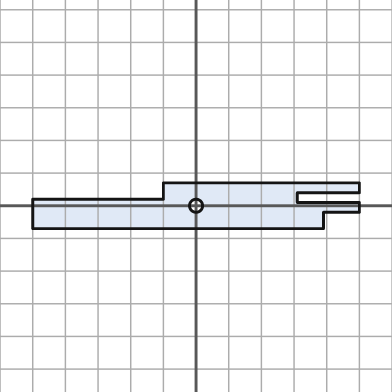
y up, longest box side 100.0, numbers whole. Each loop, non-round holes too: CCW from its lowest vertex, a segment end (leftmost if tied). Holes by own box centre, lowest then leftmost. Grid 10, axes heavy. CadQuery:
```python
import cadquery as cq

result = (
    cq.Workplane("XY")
    .moveTo(-50.0, -7.0)
    .lineTo(39.0, -7.0)
    .lineTo(39.0, -2.0)
    .lineTo(50.0, -2.0)
    .lineTo(50.0, 1.0)
    .lineTo(31.0, 1.0)
    .lineTo(31.0, 4.0)
    .lineTo(50.0, 4.0)
    .lineTo(50.0, 7.0)
    .lineTo(-10.0, 7.0)
    .lineTo(-10.0, 2.0)
    .lineTo(-50.0, 2.0)
    .close()
    .moveTo(0.0, 0.0)
    .circle(2.0)
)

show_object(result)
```